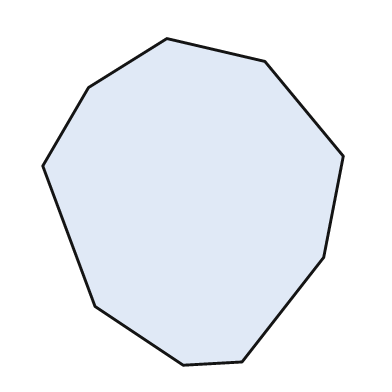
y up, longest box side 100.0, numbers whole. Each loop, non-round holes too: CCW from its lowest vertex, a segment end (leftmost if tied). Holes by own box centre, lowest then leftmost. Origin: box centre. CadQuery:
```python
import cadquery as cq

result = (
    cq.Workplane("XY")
    .moveTo(-3.0, -50.0)
    .lineTo(15.0, -49.0)
    .lineTo(40.0, -17.0)
    .lineTo(46.0, 14.0)
    .lineTo(22.0, 43.0)
    .lineTo(-8.0, 50.0)
    .lineTo(-32.0, 35.0)
    .lineTo(-46.0, 11.0)
    .lineTo(-30.0, -32.0)
    .close()
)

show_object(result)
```